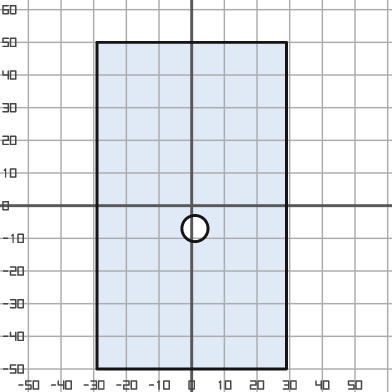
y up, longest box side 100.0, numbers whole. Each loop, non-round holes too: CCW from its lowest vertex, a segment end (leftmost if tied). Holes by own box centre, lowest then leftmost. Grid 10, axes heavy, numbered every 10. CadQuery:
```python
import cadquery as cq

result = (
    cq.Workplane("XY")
    .moveTo(-29.0, -50.0)
    .lineTo(29.0, -50.0)
    .lineTo(29.0, 50.0)
    .lineTo(-29.0, 50.0)
    .close()
    .moveTo(1.0, -7.0)
    .circle(4.0)
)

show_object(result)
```